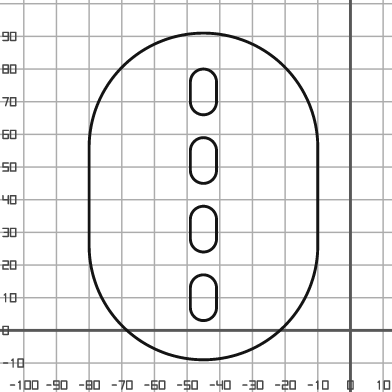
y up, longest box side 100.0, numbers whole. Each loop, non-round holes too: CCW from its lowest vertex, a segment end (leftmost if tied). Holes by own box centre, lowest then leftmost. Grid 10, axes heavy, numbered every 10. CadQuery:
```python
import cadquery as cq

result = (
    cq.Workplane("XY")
    .moveTo(-80.0, 26.0)
    .threePointArc((-45.0, -9.0), (-10.0, 26.0))
    .lineTo(-10.0, 56.0)
    .threePointArc((-45.0, 91.0), (-80.0, 56.0))
    .close()
    .moveTo(-49.0, 7.0)
    .threePointArc((-45.0, 3.0), (-41.0, 7.0))
    .lineTo(-41.0, 13.0)
    .threePointArc((-45.0, 17.0), (-49.0, 13.0))
    .close()
    .moveTo(-49.0, 28.0)
    .threePointArc((-45.0, 24.0), (-41.0, 28.0))
    .lineTo(-41.0, 34.0)
    .threePointArc((-45.0, 38.0), (-49.0, 34.0))
    .close()
    .moveTo(-49.0, 49.0)
    .threePointArc((-45.0, 45.0), (-41.0, 49.0))
    .lineTo(-41.0, 55.0)
    .threePointArc((-45.0, 59.0), (-49.0, 55.0))
    .close()
    .moveTo(-49.0, 70.0)
    .threePointArc((-45.0, 66.0), (-41.0, 70.0))
    .lineTo(-41.0, 76.0)
    .threePointArc((-45.0, 80.0), (-49.0, 76.0))
    .close()
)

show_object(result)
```